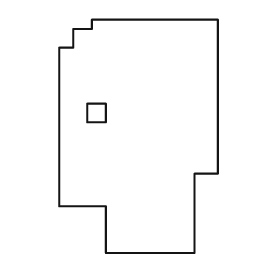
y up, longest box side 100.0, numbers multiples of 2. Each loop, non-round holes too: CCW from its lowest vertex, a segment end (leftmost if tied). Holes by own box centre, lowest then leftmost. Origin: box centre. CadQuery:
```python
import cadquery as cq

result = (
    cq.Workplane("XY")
    .moveTo(-14.0, -50.0)
    .lineTo(24.0, -50.0)
    .lineTo(24.0, -16.0)
    .lineTo(34.0, -16.0)
    .lineTo(34.0, 50.0)
    .lineTo(-20.0, 50.0)
    .lineTo(-20.0, 46.0)
    .lineTo(-28.0, 46.0)
    .lineTo(-28.0, 38.0)
    .lineTo(-34.0, 38.0)
    .lineTo(-34.0, -30.0)
    .lineTo(-14.0, -30.0)
    .close()
    .moveTo(-22.0, 6.0)
    .lineTo(-14.0, 6.0)
    .lineTo(-14.0, 14.0)
    .lineTo(-22.0, 14.0)
    .close()
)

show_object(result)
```